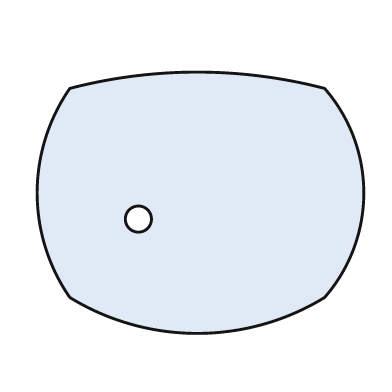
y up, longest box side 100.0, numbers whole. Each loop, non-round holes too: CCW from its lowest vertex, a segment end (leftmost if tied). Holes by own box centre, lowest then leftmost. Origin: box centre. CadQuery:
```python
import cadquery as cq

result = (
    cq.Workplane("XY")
    .moveTo(-40.0, -29.0)
    .threePointArc((-1.0, -40.0), (38.0, -29.0))
    .threePointArc((50.0, 3.0), (38.0, 35.0))
    .threePointArc((-1.0, 40.0), (-40.0, 35.0))
    .threePointArc((-50.0, 3.0), (-40.0, -29.0))
    .close()
    .moveTo(-19.0, -5.0)
    .circle(4.0)
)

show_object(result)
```